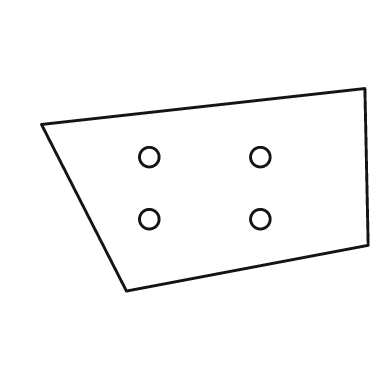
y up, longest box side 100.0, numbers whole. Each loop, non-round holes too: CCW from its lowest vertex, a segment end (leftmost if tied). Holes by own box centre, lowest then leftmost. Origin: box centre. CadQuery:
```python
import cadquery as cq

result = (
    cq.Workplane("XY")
    .moveTo(-24.0, -31.0)
    .lineTo(50.0, -17.0)
    .lineTo(49.0, 31.0)
    .lineTo(-50.0, 20.0)
    .close()
    .moveTo(-17.0, -9.0)
    .circle(3.0)
    .moveTo(17.0, -9.0)
    .circle(3.0)
    .moveTo(-17.0, 10.0)
    .circle(3.0)
    .moveTo(17.0, 10.0)
    .circle(3.0)
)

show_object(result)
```